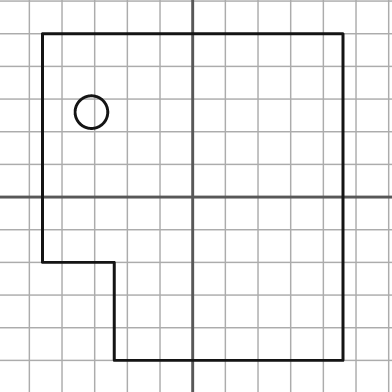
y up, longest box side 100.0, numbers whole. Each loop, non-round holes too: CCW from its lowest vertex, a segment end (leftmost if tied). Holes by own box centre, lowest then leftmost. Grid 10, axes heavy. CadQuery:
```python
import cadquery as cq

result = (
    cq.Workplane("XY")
    .moveTo(-24.0, -50.0)
    .lineTo(46.0, -50.0)
    .lineTo(46.0, 50.0)
    .lineTo(-46.0, 50.0)
    .lineTo(-46.0, -20.0)
    .lineTo(-24.0, -20.0)
    .close()
    .moveTo(-31.0, 26.0)
    .circle(5.0)
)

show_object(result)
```